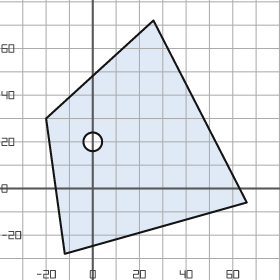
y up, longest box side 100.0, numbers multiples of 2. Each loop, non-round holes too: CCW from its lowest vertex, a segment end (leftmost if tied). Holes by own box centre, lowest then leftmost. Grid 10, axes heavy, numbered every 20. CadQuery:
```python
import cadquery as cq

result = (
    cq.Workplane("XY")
    .moveTo(-12.0, -28.0)
    .lineTo(66.0, -6.0)
    .lineTo(26.0, 72.0)
    .lineTo(-20.0, 30.0)
    .close()
    .moveTo(0.0, 20.0)
    .circle(4.0)
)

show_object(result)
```